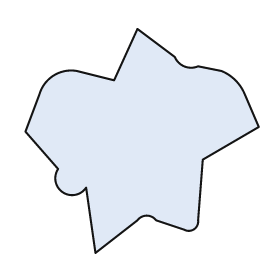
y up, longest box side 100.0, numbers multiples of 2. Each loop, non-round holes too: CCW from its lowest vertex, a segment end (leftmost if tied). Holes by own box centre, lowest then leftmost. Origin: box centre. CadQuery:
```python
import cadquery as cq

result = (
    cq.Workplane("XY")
    .moveTo(-20.0, -48.0)
    .lineTo(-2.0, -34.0)
    .threePointArc((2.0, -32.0), (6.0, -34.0))
    .lineTo(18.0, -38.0)
    .threePointArc((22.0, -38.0), (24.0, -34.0))
    .lineTo(26.0, -8.0)
    .lineTo(50.0, 6.0)
    .lineTo(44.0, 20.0)
    .threePointArc((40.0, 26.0), (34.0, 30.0))
    .lineTo(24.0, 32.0)
    .threePointArc((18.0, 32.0), (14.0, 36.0))
    .lineTo(-2.0, 48.0)
    .lineTo(-12.0, 26.0)
    .lineTo(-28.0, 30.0)
    .threePointArc((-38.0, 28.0), (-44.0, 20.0))
    .lineTo(-50.0, 4.0)
    .lineTo(-36.0, -12.0)
    .threePointArc((-34.0, -22.0), (-24.0, -20.0))
    .close()
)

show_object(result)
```